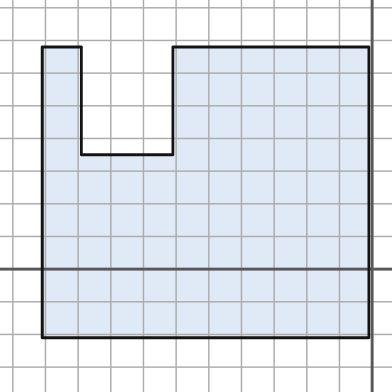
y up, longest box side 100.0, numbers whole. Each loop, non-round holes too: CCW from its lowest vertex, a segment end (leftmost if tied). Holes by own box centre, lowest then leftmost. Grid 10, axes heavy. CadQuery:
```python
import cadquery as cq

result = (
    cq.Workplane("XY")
    .moveTo(-101.0, -21.0)
    .lineTo(-1.0, -21.0)
    .lineTo(-1.0, 68.0)
    .lineTo(-61.0, 68.0)
    .lineTo(-61.0, 35.0)
    .lineTo(-89.0, 35.0)
    .lineTo(-89.0, 68.0)
    .lineTo(-101.0, 68.0)
    .close()
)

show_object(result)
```